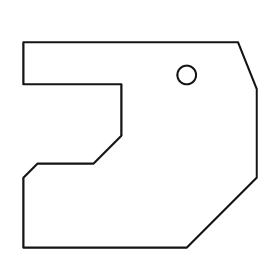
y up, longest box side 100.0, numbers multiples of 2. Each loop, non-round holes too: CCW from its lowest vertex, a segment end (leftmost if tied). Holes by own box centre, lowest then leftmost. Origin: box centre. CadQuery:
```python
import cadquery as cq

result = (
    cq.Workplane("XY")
    .moveTo(-50.0, -44.0)
    .lineTo(20.0, -44.0)
    .lineTo(50.0, -14.0)
    .lineTo(50.0, 24.0)
    .lineTo(42.0, 44.0)
    .lineTo(-50.0, 44.0)
    .lineTo(-50.0, 26.0)
    .lineTo(-8.0, 26.0)
    .lineTo(-8.0, 4.0)
    .lineTo(-20.0, -8.0)
    .lineTo(-44.0, -8.0)
    .lineTo(-50.0, -14.0)
    .close()
    .moveTo(20.0, 30.0)
    .circle(4.0)
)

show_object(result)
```